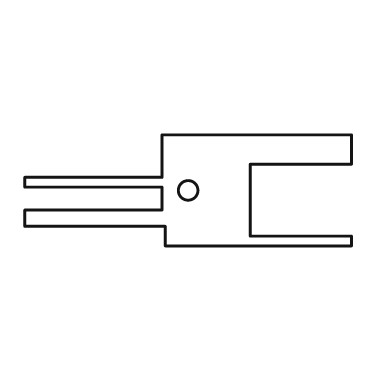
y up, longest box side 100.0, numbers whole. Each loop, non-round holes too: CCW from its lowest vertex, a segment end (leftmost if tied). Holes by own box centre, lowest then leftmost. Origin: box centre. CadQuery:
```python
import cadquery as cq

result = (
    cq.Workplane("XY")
    .moveTo(-7.0, -17.0)
    .lineTo(50.0, -17.0)
    .lineTo(50.0, -14.0)
    .lineTo(19.0, -14.0)
    .lineTo(19.0, 8.0)
    .lineTo(50.0, 8.0)
    .lineTo(50.0, 17.0)
    .lineTo(-8.0, 17.0)
    .lineTo(-8.0, 4.0)
    .lineTo(-50.0, 4.0)
    .lineTo(-50.0, 1.0)
    .lineTo(-8.0, 1.0)
    .lineTo(-8.0, -6.0)
    .lineTo(-50.0, -6.0)
    .lineTo(-50.0, -11.0)
    .lineTo(-7.0, -11.0)
    .close()
    .moveTo(0.0, 0.0)
    .circle(3.0)
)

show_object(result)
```